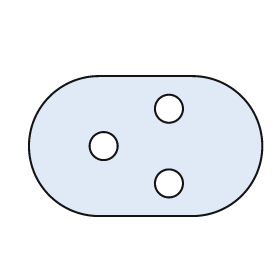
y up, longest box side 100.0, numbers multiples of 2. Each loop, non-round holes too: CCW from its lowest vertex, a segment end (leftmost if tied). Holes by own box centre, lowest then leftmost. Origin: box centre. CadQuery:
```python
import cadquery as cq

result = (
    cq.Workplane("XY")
    .moveTo(-20.0, -30.0)
    .lineTo(20.0, -30.0)
    .threePointArc((50.0, 0.0), (20.0, 30.0))
    .lineTo(-20.0, 30.0)
    .threePointArc((-50.0, 0.0), (-20.0, -30.0))
    .close()
    .moveTo(10.0, -16.0)
    .circle(6.0)
    .moveTo(-18.0, 0.0)
    .circle(6.0)
    .moveTo(10.0, 16.0)
    .circle(6.0)
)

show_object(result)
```